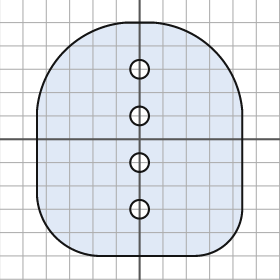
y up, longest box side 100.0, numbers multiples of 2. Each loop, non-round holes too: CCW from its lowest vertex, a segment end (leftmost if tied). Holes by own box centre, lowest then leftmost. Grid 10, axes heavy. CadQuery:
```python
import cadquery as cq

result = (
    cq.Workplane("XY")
    .moveTo(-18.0, -50.0)
    .lineTo(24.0, -50.0)
    .threePointArc((38.0, -44.0), (44.0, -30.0))
    .lineTo(44.0, 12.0)
    .threePointArc((32.0, 38.0), (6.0, 50.0))
    .lineTo(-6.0, 50.0)
    .threePointArc((-32.0, 38.0), (-44.0, 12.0))
    .lineTo(-44.0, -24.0)
    .threePointArc((-36.0, -42.0), (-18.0, -50.0))
    .close()
    .moveTo(0.0, -30.0)
    .circle(4.0)
    .moveTo(0.0, -10.0)
    .circle(4.0)
    .moveTo(0.0, 10.0)
    .circle(4.0)
    .moveTo(0.0, 30.0)
    .circle(4.0)
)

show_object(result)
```